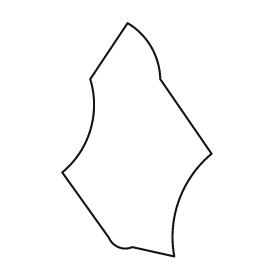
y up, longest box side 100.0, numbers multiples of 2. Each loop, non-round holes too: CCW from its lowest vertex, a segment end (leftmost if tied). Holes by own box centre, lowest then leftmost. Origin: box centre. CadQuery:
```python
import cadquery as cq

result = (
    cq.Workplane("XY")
    .moveTo(16.0, -50.0)
    .threePointArc((18.0, -26.0), (32.0, -6.0))
    .lineTo(10.0, 26.0)
    .threePointArc((6.0, 40.0), (-4.0, 50.0))
    .lineTo(-20.0, 26.0)
    .threePointArc((-20.0, 4.0), (-32.0, -14.0))
    .lineTo(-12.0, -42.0)
    .threePointArc((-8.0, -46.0), (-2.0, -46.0))
    .close()
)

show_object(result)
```